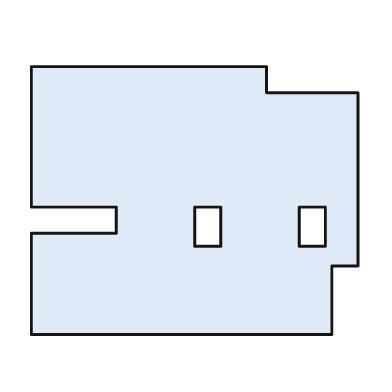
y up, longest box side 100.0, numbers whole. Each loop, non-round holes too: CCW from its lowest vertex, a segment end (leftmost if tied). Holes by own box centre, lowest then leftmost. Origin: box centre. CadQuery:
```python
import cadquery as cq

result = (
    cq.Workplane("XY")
    .moveTo(-50.0, -41.0)
    .lineTo(42.0, -41.0)
    .lineTo(42.0, -20.0)
    .lineTo(50.0, -20.0)
    .lineTo(50.0, 33.0)
    .lineTo(22.0, 33.0)
    .lineTo(22.0, 41.0)
    .lineTo(-50.0, 41.0)
    .lineTo(-50.0, -2.0)
    .lineTo(-24.0, -2.0)
    .lineTo(-24.0, -10.0)
    .lineTo(-50.0, -10.0)
    .close()
    .moveTo(0.0, -14.0)
    .lineTo(8.0, -14.0)
    .lineTo(8.0, -2.0)
    .lineTo(0.0, -2.0)
    .close()
    .moveTo(32.0, -14.0)
    .lineTo(40.0, -14.0)
    .lineTo(40.0, -2.0)
    .lineTo(32.0, -2.0)
    .close()
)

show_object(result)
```